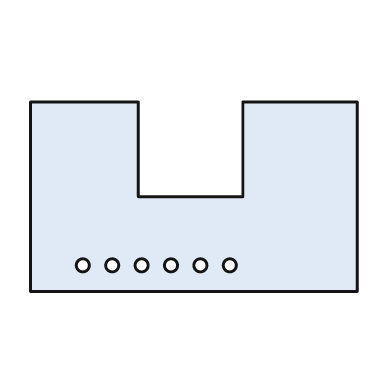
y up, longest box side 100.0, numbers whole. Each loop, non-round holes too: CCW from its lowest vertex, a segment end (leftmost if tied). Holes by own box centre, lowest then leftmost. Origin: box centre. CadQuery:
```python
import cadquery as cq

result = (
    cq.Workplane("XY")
    .moveTo(-50.0, -29.0)
    .lineTo(50.0, -29.0)
    .lineTo(50.0, 29.0)
    .lineTo(15.0, 29.0)
    .lineTo(15.0, 0.0)
    .lineTo(-17.0, 0.0)
    .lineTo(-17.0, 29.0)
    .lineTo(-50.0, 29.0)
    .close()
    .moveTo(-34.0, -21.0)
    .circle(2.0)
    .moveTo(-25.0, -21.0)
    .circle(2.0)
    .moveTo(-16.0, -21.0)
    .circle(2.0)
    .moveTo(-7.0, -21.0)
    .circle(2.0)
    .moveTo(2.0, -21.0)
    .circle(2.0)
    .moveTo(11.0, -21.0)
    .circle(2.0)
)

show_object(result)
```